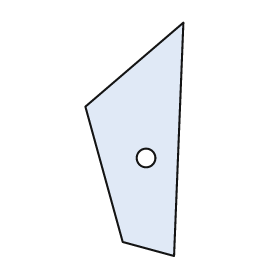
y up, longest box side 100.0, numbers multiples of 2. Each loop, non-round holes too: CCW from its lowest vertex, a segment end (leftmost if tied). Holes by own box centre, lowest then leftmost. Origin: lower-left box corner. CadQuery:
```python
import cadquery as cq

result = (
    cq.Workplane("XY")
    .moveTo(38.0, 0.0)
    .lineTo(42.0, 100.0)
    .lineTo(0.0, 64.0)
    .lineTo(16.0, 6.0)
    .close()
    .moveTo(26.0, 42.0)
    .circle(4.0)
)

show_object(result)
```